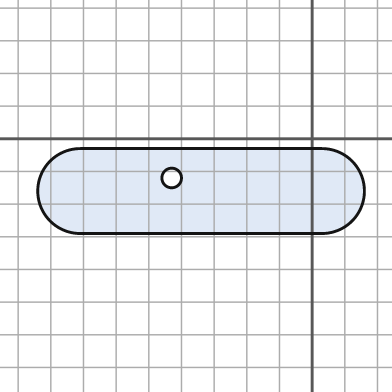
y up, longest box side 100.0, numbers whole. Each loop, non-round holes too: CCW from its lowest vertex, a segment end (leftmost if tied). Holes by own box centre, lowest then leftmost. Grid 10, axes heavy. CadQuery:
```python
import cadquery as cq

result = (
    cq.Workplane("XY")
    .moveTo(-71.0, -29.0)
    .lineTo(3.0, -29.0)
    .threePointArc((16.0, -16.0), (3.0, -3.0))
    .lineTo(-71.0, -3.0)
    .threePointArc((-84.0, -16.0), (-71.0, -29.0))
    .close()
    .moveTo(-43.0, -12.0)
    .circle(3.0)
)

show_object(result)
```